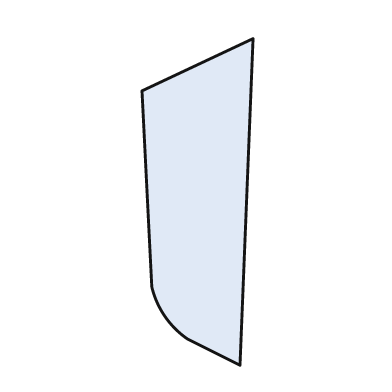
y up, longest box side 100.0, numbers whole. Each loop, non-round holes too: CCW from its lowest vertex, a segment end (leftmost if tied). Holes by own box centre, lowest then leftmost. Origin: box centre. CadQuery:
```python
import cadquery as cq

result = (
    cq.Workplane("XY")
    .moveTo(13.0, -50.0)
    .lineTo(17.0, 50.0)
    .lineTo(-17.0, 34.0)
    .lineTo(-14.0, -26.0)
    .threePointArc((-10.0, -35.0), (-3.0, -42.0))
    .close()
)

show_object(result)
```